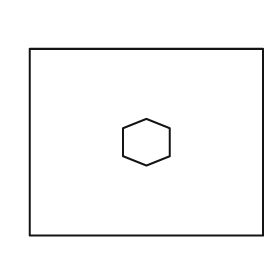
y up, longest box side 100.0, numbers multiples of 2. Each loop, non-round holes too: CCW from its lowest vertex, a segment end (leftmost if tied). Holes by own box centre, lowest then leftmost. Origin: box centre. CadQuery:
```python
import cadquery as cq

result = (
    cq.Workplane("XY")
    .moveTo(-50.0, -40.0)
    .lineTo(50.0, -40.0)
    .lineTo(50.0, 40.0)
    .lineTo(-50.0, 40.0)
    .close()
    .moveTo(0.0, -10.0)
    .lineTo(10.0, -6.0)
    .lineTo(10.0, 6.0)
    .lineTo(0.0, 10.0)
    .lineTo(-10.0, 6.0)
    .lineTo(-10.0, -6.0)
    .close()
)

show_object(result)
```